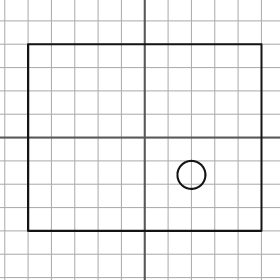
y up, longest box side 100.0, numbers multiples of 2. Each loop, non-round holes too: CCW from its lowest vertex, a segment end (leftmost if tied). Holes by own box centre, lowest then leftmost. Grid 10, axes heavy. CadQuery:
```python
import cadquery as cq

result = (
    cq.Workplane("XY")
    .moveTo(-50.0, -40.0)
    .lineTo(50.0, -40.0)
    .lineTo(50.0, 40.0)
    .lineTo(-50.0, 40.0)
    .close()
    .moveTo(20.0, -16.0)
    .circle(6.0)
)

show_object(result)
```